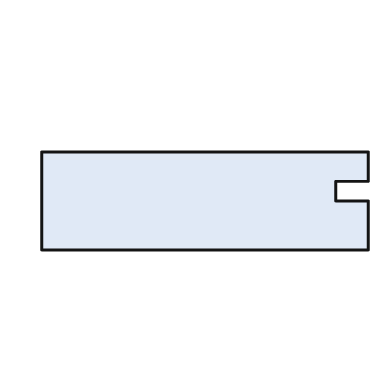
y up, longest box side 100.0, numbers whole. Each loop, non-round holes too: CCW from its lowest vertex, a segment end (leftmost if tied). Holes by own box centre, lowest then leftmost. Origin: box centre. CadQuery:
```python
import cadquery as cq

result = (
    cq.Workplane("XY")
    .moveTo(-50.0, -15.0)
    .lineTo(50.0, -15.0)
    .lineTo(50.0, 0.0)
    .lineTo(40.0, 0.0)
    .lineTo(40.0, 6.0)
    .lineTo(50.0, 6.0)
    .lineTo(50.0, 15.0)
    .lineTo(-50.0, 15.0)
    .close()
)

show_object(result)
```